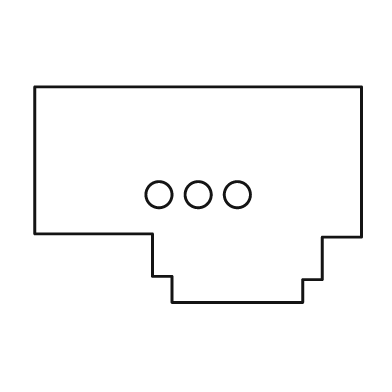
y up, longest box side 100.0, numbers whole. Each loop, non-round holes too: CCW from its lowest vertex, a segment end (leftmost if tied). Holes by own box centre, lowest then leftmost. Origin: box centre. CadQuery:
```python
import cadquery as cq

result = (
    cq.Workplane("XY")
    .moveTo(-8.0, -33.0)
    .lineTo(32.0, -33.0)
    .lineTo(32.0, -26.0)
    .lineTo(38.0, -26.0)
    .lineTo(38.0, -13.0)
    .lineTo(50.0, -13.0)
    .lineTo(50.0, 33.0)
    .lineTo(-50.0, 33.0)
    .lineTo(-50.0, -12.0)
    .lineTo(-14.0, -12.0)
    .lineTo(-14.0, -25.0)
    .lineTo(-8.0, -25.0)
    .close()
    .moveTo(-12.0, 0.0)
    .circle(4.0)
    .moveTo(0.0, 0.0)
    .circle(4.0)
    .moveTo(12.0, 0.0)
    .circle(4.0)
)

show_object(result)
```